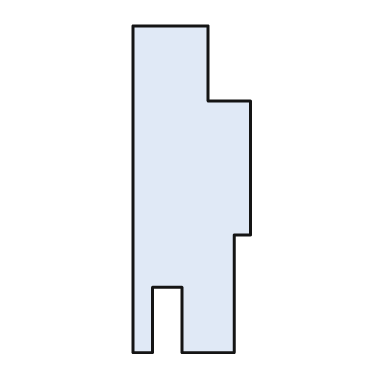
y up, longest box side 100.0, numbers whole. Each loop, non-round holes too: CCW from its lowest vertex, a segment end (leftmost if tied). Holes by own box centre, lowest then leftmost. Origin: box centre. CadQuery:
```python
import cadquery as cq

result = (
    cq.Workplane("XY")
    .moveTo(-18.0, -50.0)
    .lineTo(-12.0, -50.0)
    .lineTo(-12.0, -30.0)
    .lineTo(-3.0, -30.0)
    .lineTo(-3.0, -50.0)
    .lineTo(13.0, -50.0)
    .lineTo(13.0, -14.0)
    .lineTo(18.0, -14.0)
    .lineTo(18.0, 27.0)
    .lineTo(5.0, 27.0)
    .lineTo(5.0, 50.0)
    .lineTo(-18.0, 50.0)
    .close()
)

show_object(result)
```